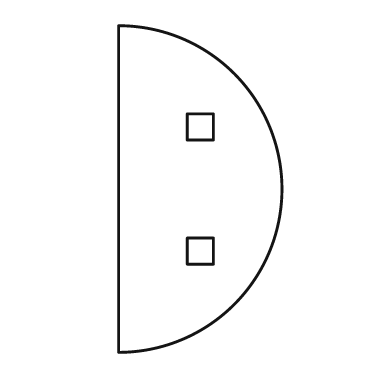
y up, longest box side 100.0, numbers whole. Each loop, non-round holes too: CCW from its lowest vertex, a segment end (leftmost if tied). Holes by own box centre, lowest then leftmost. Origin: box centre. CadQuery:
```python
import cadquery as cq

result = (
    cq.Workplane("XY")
    .moveTo(-25.0, -50.0)
    .threePointArc((25.0, 0.0), (-25.0, 50.0))
    .close()
    .moveTo(-4.0, -23.0)
    .lineTo(4.0, -23.0)
    .lineTo(4.0, -15.0)
    .lineTo(-4.0, -15.0)
    .close()
    .moveTo(-4.0, 15.0)
    .lineTo(4.0, 15.0)
    .lineTo(4.0, 23.0)
    .lineTo(-4.0, 23.0)
    .close()
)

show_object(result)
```